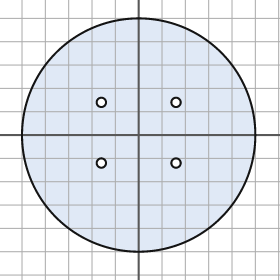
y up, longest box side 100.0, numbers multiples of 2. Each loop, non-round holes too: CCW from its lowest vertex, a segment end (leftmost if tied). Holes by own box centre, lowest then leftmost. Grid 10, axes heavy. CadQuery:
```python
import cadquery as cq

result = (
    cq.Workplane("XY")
    .moveTo(0.0, 0.0)
    .circle(50.0)
    .moveTo(-16.0, -12.0)
    .circle(2.0)
    .moveTo(16.0, -12.0)
    .circle(2.0)
    .moveTo(-16.0, 14.0)
    .circle(2.0)
    .moveTo(16.0, 14.0)
    .circle(2.0)
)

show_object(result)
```